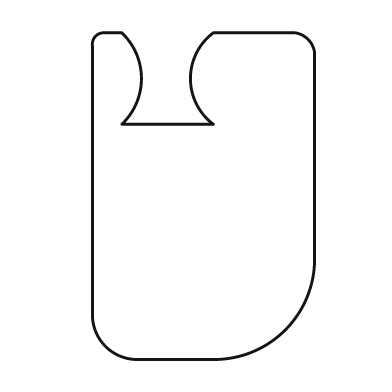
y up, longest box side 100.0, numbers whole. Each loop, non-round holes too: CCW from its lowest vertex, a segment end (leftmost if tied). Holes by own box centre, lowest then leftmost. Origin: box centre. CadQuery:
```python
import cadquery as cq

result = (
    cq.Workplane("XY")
    .moveTo(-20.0, -50.0)
    .lineTo(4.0, -50.0)
    .threePointArc((25.0, -41.0), (34.0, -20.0))
    .lineTo(34.0, 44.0)
    .threePointArc((32.0, 48.0), (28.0, 50.0))
    .lineTo(3.0, 50.0)
    .threePointArc((-4.0, 36.0), (3.0, 22.0))
    .lineTo(-25.0, 22.0)
    .threePointArc((-19.0, 36.0), (-25.0, 50.0))
    .lineTo(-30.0, 50.0)
    .threePointArc((-33.0, 49.0), (-34.0, 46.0))
    .lineTo(-34.0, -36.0)
    .threePointArc((-30.0, -46.0), (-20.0, -50.0))
    .close()
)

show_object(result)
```